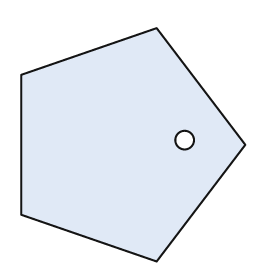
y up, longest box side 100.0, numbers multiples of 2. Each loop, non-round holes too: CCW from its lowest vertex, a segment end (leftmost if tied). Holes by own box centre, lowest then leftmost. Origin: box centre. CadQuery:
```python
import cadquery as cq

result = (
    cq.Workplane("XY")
    .moveTo(10.0, -50.0)
    .lineTo(48.0, 0.0)
    .lineTo(10.0, 50.0)
    .lineTo(-48.0, 30.0)
    .lineTo(-48.0, -30.0)
    .close()
    .moveTo(22.0, 2.0)
    .circle(4.0)
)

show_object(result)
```